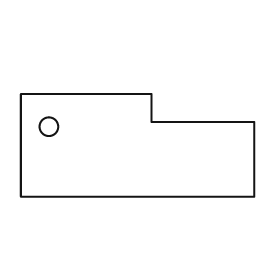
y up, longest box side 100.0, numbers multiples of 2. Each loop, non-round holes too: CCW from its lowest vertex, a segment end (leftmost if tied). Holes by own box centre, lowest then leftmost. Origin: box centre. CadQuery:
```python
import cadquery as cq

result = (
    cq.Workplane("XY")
    .moveTo(-50.0, -22.0)
    .lineTo(50.0, -22.0)
    .lineTo(50.0, 10.0)
    .lineTo(6.0, 10.0)
    .lineTo(6.0, 22.0)
    .lineTo(-50.0, 22.0)
    .close()
    .moveTo(-38.0, 8.0)
    .circle(4.0)
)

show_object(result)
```